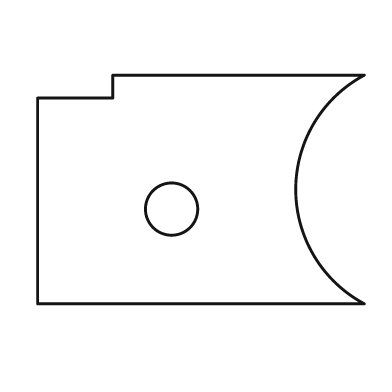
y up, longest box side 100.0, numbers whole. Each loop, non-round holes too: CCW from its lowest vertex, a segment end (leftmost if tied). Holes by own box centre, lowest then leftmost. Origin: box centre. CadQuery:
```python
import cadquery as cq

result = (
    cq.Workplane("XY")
    .moveTo(-50.0, -35.0)
    .lineTo(50.0, -35.0)
    .threePointArc((29.0, 0.0), (50.0, 35.0))
    .lineTo(-27.0, 35.0)
    .lineTo(-27.0, 28.0)
    .lineTo(-50.0, 28.0)
    .close()
    .moveTo(-9.0, -6.0)
    .circle(8.0)
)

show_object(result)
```